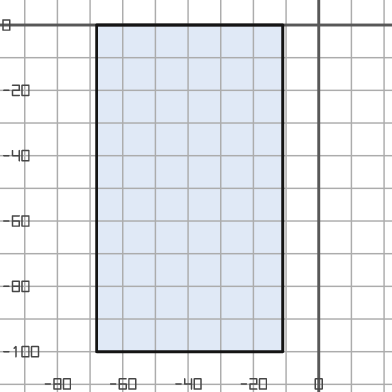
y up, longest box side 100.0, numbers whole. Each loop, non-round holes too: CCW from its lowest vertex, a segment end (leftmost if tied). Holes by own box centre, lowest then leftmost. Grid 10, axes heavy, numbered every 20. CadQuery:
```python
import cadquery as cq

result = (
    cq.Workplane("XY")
    .moveTo(-68.0, -100.0)
    .lineTo(-11.0, -100.0)
    .lineTo(-11.0, 0.0)
    .lineTo(-68.0, 0.0)
    .close()
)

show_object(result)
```